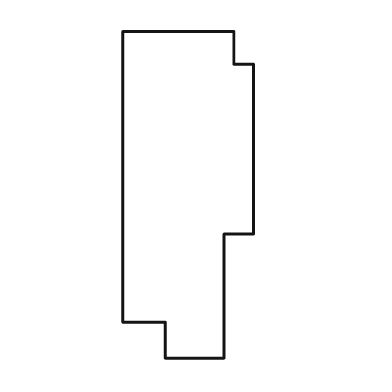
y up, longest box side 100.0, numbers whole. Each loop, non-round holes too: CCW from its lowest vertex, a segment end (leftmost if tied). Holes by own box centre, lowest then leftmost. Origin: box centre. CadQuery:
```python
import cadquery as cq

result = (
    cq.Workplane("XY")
    .moveTo(-7.0, -50.0)
    .lineTo(11.0, -50.0)
    .lineTo(11.0, -12.0)
    .lineTo(20.0, -12.0)
    .lineTo(20.0, 40.0)
    .lineTo(14.0, 40.0)
    .lineTo(14.0, 50.0)
    .lineTo(-20.0, 50.0)
    .lineTo(-20.0, -39.0)
    .lineTo(-7.0, -39.0)
    .close()
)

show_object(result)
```